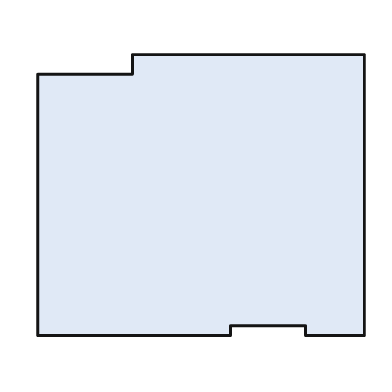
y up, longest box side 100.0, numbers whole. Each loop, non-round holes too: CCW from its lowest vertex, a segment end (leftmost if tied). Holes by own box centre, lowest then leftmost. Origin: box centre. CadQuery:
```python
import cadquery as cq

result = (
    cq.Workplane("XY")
    .moveTo(-50.0, -43.0)
    .lineTo(9.0, -43.0)
    .lineTo(9.0, -40.0)
    .lineTo(32.0, -40.0)
    .lineTo(32.0, -43.0)
    .lineTo(50.0, -43.0)
    .lineTo(50.0, 43.0)
    .lineTo(-21.0, 43.0)
    .lineTo(-21.0, 37.0)
    .lineTo(-50.0, 37.0)
    .close()
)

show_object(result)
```